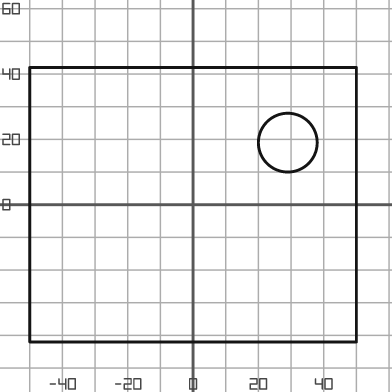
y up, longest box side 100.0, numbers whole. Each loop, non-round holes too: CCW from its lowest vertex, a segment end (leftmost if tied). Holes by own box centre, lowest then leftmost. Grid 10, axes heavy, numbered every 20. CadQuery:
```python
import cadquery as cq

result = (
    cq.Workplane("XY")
    .moveTo(-50.0, -42.0)
    .lineTo(50.0, -42.0)
    .lineTo(50.0, 42.0)
    .lineTo(-50.0, 42.0)
    .close()
    .moveTo(29.0, 19.0)
    .circle(9.0)
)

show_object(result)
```